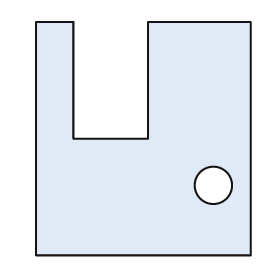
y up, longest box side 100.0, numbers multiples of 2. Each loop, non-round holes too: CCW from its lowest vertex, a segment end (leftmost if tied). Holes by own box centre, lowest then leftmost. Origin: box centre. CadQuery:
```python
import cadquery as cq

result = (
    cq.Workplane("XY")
    .moveTo(-46.0, -50.0)
    .lineTo(46.0, -50.0)
    .lineTo(46.0, 50.0)
    .lineTo(2.0, 50.0)
    .lineTo(2.0, 0.0)
    .lineTo(-30.0, 0.0)
    .lineTo(-30.0, 50.0)
    .lineTo(-46.0, 50.0)
    .close()
    .moveTo(30.0, -20.0)
    .circle(8.0)
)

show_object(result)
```